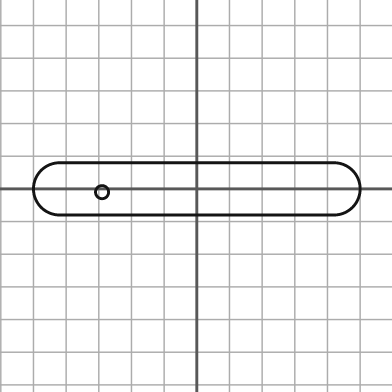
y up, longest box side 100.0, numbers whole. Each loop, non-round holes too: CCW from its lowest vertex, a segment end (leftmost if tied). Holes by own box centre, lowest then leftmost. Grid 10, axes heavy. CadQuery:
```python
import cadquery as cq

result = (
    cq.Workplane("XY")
    .moveTo(-42.0, -8.0)
    .lineTo(42.0, -8.0)
    .threePointArc((50.0, 0.0), (42.0, 8.0))
    .lineTo(-42.0, 8.0)
    .threePointArc((-50.0, 0.0), (-42.0, -8.0))
    .close()
    .moveTo(-29.0, -1.0)
    .circle(2.0)
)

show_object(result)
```